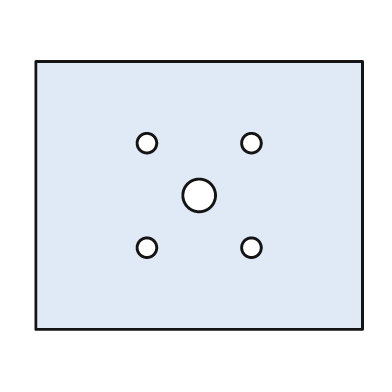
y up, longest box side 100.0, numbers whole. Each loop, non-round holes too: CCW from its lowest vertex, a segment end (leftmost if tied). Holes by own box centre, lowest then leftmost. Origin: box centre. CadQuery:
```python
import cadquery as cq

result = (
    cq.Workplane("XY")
    .moveTo(-50.0, -41.0)
    .lineTo(50.0, -41.0)
    .lineTo(50.0, 41.0)
    .lineTo(-50.0, 41.0)
    .close()
    .moveTo(-16.0, -16.0)
    .circle(3.0)
    .moveTo(16.0, -16.0)
    .circle(3.0)
    .moveTo(0.0, 0.0)
    .circle(5.0)
    .moveTo(-16.0, 16.0)
    .circle(3.0)
    .moveTo(16.0, 16.0)
    .circle(3.0)
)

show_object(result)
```